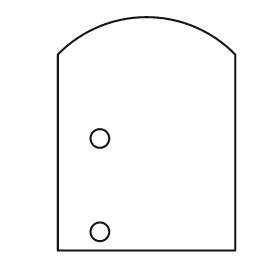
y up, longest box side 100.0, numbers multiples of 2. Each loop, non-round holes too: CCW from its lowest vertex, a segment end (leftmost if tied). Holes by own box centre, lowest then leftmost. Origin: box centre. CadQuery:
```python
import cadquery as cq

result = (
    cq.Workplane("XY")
    .moveTo(-38.0, -50.0)
    .lineTo(38.0, -50.0)
    .lineTo(38.0, 34.0)
    .threePointArc((0.0, 50.0), (-38.0, 34.0))
    .close()
    .moveTo(-20.0, -42.0)
    .circle(4.0)
    .moveTo(-20.0, -2.0)
    .circle(4.0)
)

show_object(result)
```